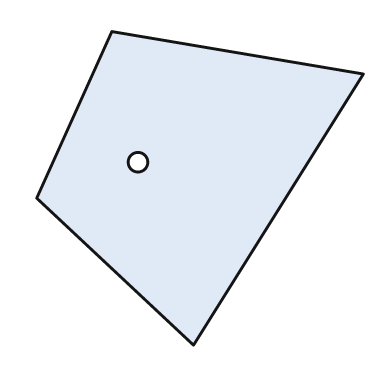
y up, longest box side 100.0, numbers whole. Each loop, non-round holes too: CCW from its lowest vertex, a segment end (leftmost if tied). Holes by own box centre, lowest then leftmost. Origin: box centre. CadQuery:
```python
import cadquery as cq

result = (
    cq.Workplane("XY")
    .moveTo(-2.0, -48.0)
    .lineTo(50.0, 35.0)
    .lineTo(-27.0, 48.0)
    .lineTo(-50.0, -3.0)
    .close()
    .moveTo(-19.0, 8.0)
    .circle(3.0)
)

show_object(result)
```